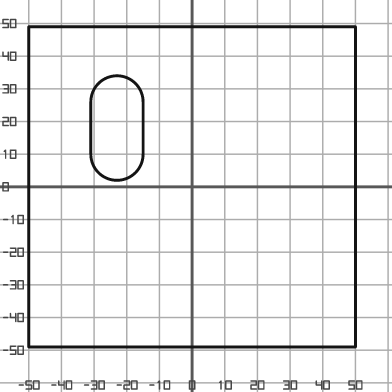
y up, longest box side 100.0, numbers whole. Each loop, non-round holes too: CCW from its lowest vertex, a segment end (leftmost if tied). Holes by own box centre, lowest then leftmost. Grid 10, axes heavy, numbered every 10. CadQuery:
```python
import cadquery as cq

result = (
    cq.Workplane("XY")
    .moveTo(-50.0, -49.0)
    .lineTo(50.0, -49.0)
    .lineTo(50.0, 49.0)
    .lineTo(-50.0, 49.0)
    .close()
    .moveTo(-31.0, 10.0)
    .threePointArc((-23.0, 2.0), (-15.0, 10.0))
    .lineTo(-15.0, 26.0)
    .threePointArc((-23.0, 34.0), (-31.0, 26.0))
    .close()
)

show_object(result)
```